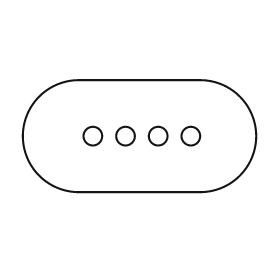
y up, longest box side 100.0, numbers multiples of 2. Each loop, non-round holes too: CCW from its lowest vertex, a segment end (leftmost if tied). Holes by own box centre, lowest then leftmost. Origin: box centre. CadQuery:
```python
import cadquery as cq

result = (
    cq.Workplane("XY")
    .moveTo(-26.0, -24.0)
    .lineTo(26.0, -24.0)
    .threePointArc((50.0, 0.0), (26.0, 24.0))
    .lineTo(-26.0, 24.0)
    .threePointArc((-50.0, 0.0), (-26.0, -24.0))
    .close()
    .moveTo(-20.0, 0.0)
    .circle(4.0)
    .moveTo(-6.0, 0.0)
    .circle(4.0)
    .moveTo(8.0, 0.0)
    .circle(4.0)
    .moveTo(22.0, 0.0)
    .circle(4.0)
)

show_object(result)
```